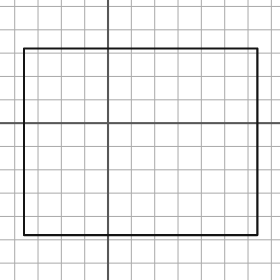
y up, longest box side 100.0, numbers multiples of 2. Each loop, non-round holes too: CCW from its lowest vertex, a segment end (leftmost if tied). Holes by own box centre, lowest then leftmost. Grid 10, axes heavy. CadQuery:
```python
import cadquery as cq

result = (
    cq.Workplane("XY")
    .moveTo(-36.0, -48.0)
    .lineTo(64.0, -48.0)
    .lineTo(64.0, 32.0)
    .lineTo(-36.0, 32.0)
    .close()
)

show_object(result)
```